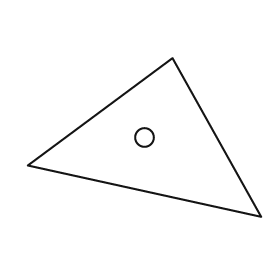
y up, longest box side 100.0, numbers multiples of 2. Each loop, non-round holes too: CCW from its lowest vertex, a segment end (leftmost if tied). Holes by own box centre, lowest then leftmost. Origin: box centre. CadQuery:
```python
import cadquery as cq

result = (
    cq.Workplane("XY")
    .moveTo(50.0, -34.0)
    .lineTo(12.0, 34.0)
    .lineTo(-50.0, -12.0)
    .close()
    .moveTo(0.0, 0.0)
    .circle(4.0)
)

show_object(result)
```